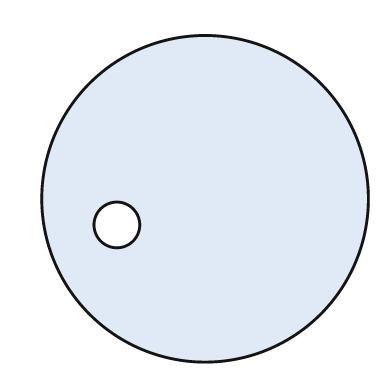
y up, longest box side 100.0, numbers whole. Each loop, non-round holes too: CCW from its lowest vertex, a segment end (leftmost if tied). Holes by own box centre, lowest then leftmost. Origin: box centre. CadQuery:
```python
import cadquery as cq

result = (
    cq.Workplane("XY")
    .moveTo(0.0, 0.0)
    .circle(50.0)
    .moveTo(-27.0, -8.0)
    .circle(7.0)
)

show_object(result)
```